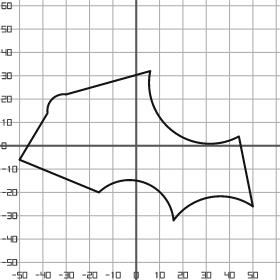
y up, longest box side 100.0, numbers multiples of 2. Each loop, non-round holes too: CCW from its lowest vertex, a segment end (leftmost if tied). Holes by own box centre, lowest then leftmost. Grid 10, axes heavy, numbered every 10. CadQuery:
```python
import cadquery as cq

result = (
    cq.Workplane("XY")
    .moveTo(16.0, -32.0)
    .threePointArc((32.0, -22.0), (50.0, -26.0))
    .lineTo(44.0, 4.0)
    .threePointArc((16.0, 6.0), (6.0, 32.0))
    .lineTo(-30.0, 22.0)
    .threePointArc((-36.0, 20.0), (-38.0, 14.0))
    .lineTo(-50.0, -6.0)
    .lineTo(-16.0, -20.0)
    .threePointArc((4.0, -16.0), (16.0, -32.0))
    .close()
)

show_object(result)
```